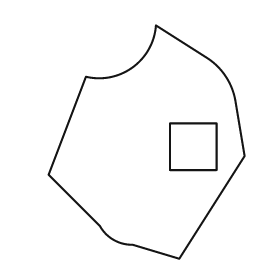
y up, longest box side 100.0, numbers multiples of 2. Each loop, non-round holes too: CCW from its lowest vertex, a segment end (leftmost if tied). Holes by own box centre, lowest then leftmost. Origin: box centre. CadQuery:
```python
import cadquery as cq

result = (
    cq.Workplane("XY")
    .moveTo(14.0, -50.0)
    .lineTo(42.0, -6.0)
    .lineTo(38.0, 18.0)
    .threePointArc((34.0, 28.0), (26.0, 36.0))
    .lineTo(4.0, 50.0)
    .threePointArc((-6.0, 32.0), (-26.0, 28.0))
    .lineTo(-42.0, -14.0)
    .lineTo(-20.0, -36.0)
    .threePointArc((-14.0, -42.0), (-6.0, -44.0))
    .close()
    .moveTo(10.0, -12.0)
    .lineTo(30.0, -12.0)
    .lineTo(30.0, 8.0)
    .lineTo(10.0, 8.0)
    .close()
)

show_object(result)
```